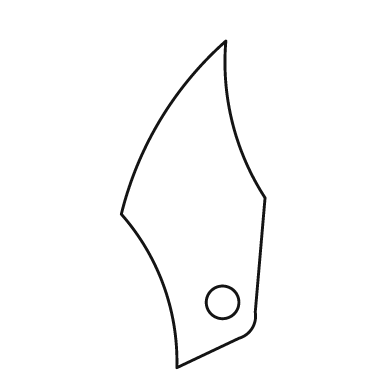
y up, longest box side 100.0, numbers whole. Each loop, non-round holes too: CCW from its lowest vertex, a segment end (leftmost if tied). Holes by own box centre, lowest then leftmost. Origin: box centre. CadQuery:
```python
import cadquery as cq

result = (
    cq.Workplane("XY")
    .moveTo(-5.0, -50.0)
    .lineTo(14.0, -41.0)
    .threePointArc((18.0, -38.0), (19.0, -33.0))
    .lineTo(22.0, 2.0)
    .threePointArc((12.0, 25.0), (10.0, 50.0))
    .threePointArc((-10.0, 26.0), (-22.0, -3.0))
    .threePointArc((-9.0, -25.0), (-5.0, -50.0))
    .close()
    .moveTo(9.0, -30.0)
    .circle(5.0)
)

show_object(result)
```